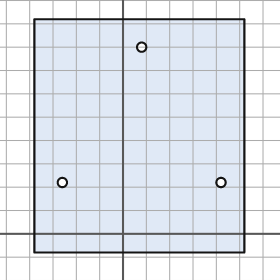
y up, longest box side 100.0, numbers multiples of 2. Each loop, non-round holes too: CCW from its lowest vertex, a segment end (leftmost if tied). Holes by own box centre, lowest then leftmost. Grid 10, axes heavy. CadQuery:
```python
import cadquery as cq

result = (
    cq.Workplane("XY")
    .moveTo(-38.0, -8.0)
    .lineTo(52.0, -8.0)
    .lineTo(52.0, 92.0)
    .lineTo(-38.0, 92.0)
    .close()
    .moveTo(-26.0, 22.0)
    .circle(2.0)
    .moveTo(42.0, 22.0)
    .circle(2.0)
    .moveTo(8.0, 80.0)
    .circle(2.0)
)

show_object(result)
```